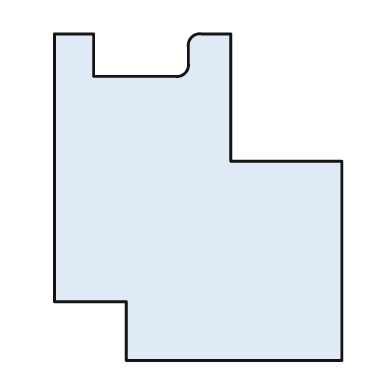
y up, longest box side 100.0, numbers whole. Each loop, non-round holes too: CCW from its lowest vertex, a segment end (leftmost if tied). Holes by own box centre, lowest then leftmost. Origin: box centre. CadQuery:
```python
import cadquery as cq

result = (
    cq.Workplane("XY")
    .moveTo(-22.0, -50.0)
    .lineTo(44.0, -50.0)
    .lineTo(44.0, 11.0)
    .lineTo(10.0, 11.0)
    .lineTo(10.0, 50.0)
    .lineTo(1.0, 50.0)
    .threePointArc((-2.0, 49.0), (-3.0, 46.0))
    .lineTo(-3.0, 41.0)
    .threePointArc((-4.0, 38.0), (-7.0, 37.0))
    .lineTo(-32.0, 37.0)
    .lineTo(-32.0, 50.0)
    .lineTo(-44.0, 50.0)
    .lineTo(-44.0, -32.0)
    .lineTo(-22.0, -32.0)
    .close()
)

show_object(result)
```